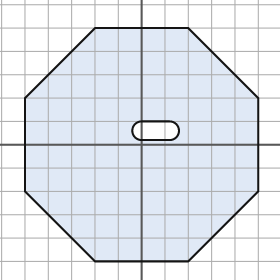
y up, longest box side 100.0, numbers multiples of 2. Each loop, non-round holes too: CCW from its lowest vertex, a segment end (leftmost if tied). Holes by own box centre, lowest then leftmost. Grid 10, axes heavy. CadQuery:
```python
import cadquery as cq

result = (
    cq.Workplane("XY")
    .moveTo(-20.0, -50.0)
    .lineTo(20.0, -50.0)
    .lineTo(50.0, -20.0)
    .lineTo(50.0, 20.0)
    .lineTo(20.0, 50.0)
    .lineTo(-20.0, 50.0)
    .lineTo(-50.0, 20.0)
    .lineTo(-50.0, -20.0)
    .close()
    .moveTo(0.0, 2.0)
    .lineTo(12.0, 2.0)
    .threePointArc((16.0, 6.0), (12.0, 10.0))
    .lineTo(0.0, 10.0)
    .threePointArc((-4.0, 6.0), (0.0, 2.0))
    .close()
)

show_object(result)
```